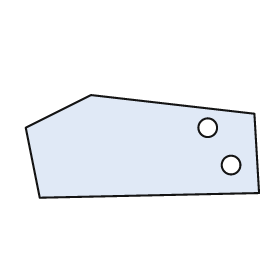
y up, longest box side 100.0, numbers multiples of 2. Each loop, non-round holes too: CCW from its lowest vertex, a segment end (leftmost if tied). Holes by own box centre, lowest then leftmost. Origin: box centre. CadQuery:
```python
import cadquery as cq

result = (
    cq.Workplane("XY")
    .moveTo(-44.0, -22.0)
    .lineTo(50.0, -20.0)
    .lineTo(48.0, 14.0)
    .lineTo(-22.0, 22.0)
    .lineTo(-50.0, 8.0)
    .close()
    .moveTo(38.0, -8.0)
    .circle(4.0)
    .moveTo(28.0, 8.0)
    .circle(4.0)
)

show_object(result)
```